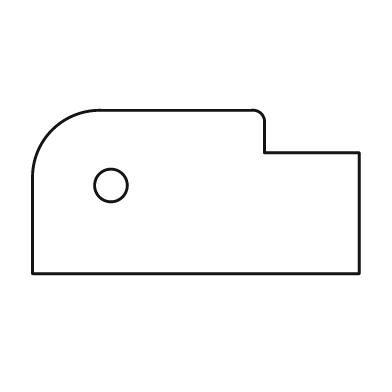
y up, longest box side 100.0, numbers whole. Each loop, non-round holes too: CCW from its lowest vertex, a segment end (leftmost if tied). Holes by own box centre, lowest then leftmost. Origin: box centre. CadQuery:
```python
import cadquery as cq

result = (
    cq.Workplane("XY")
    .moveTo(-50.0, -25.0)
    .lineTo(50.0, -25.0)
    .lineTo(50.0, 12.0)
    .lineTo(21.0, 12.0)
    .lineTo(21.0, 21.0)
    .threePointArc((20.0, 24.0), (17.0, 25.0))
    .lineTo(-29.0, 25.0)
    .threePointArc((-44.0, 19.0), (-50.0, 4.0))
    .close()
    .moveTo(-26.0, 2.0)
    .circle(5.0)
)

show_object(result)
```